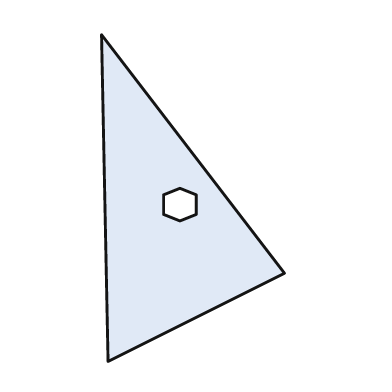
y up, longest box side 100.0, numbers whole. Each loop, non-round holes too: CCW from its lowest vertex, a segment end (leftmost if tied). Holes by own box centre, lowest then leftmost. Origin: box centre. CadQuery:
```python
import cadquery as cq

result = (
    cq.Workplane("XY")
    .moveTo(-26.0, -50.0)
    .lineTo(28.0, -23.0)
    .lineTo(-28.0, 50.0)
    .close()
    .moveTo(-4.0, -7.0)
    .lineTo(1.0, -5.0)
    .lineTo(1.0, 1.0)
    .lineTo(-4.0, 3.0)
    .lineTo(-9.0, 1.0)
    .lineTo(-9.0, -5.0)
    .close()
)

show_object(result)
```